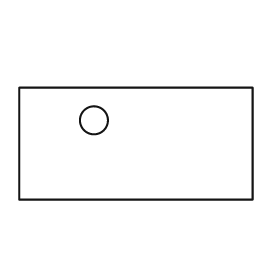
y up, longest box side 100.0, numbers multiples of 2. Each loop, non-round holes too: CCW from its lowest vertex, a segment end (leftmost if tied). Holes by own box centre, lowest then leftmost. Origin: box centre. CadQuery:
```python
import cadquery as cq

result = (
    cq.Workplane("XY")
    .moveTo(-50.0, -24.0)
    .lineTo(50.0, -24.0)
    .lineTo(50.0, 24.0)
    .lineTo(-50.0, 24.0)
    .close()
    .moveTo(-18.0, 10.0)
    .circle(6.0)
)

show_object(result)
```